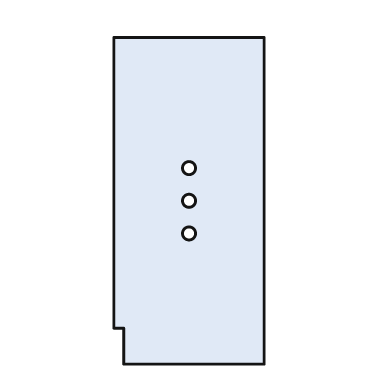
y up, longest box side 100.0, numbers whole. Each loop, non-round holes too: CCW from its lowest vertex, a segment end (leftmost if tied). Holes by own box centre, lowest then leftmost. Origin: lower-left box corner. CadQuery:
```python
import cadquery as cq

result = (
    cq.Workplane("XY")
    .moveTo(3.0, 0.0)
    .lineTo(46.0, 0.0)
    .lineTo(46.0, 100.0)
    .lineTo(0.0, 100.0)
    .lineTo(0.0, 11.0)
    .lineTo(3.0, 11.0)
    .close()
    .moveTo(23.0, 40.0)
    .circle(2.0)
    .moveTo(23.0, 50.0)
    .circle(2.0)
    .moveTo(23.0, 60.0)
    .circle(2.0)
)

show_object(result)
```